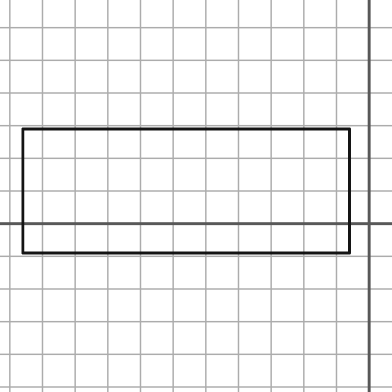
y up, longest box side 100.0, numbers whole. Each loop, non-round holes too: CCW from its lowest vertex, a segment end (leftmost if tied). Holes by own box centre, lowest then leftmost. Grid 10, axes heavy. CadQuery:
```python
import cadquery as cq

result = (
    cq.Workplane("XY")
    .moveTo(-106.0, -9.0)
    .lineTo(-6.0, -9.0)
    .lineTo(-6.0, 29.0)
    .lineTo(-106.0, 29.0)
    .close()
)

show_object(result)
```